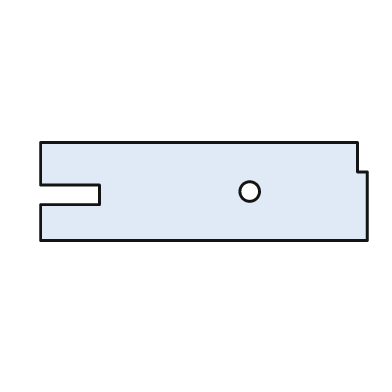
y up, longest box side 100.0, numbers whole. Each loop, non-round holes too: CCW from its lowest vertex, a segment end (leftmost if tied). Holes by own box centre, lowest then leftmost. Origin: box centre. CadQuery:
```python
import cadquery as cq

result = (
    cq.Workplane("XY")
    .moveTo(-50.0, -15.0)
    .lineTo(50.0, -15.0)
    .lineTo(50.0, 6.0)
    .lineTo(47.0, 6.0)
    .lineTo(47.0, 15.0)
    .lineTo(-50.0, 15.0)
    .lineTo(-50.0, 2.0)
    .lineTo(-32.0, 2.0)
    .lineTo(-32.0, -4.0)
    .lineTo(-50.0, -4.0)
    .close()
    .moveTo(14.0, 0.0)
    .circle(3.0)
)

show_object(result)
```